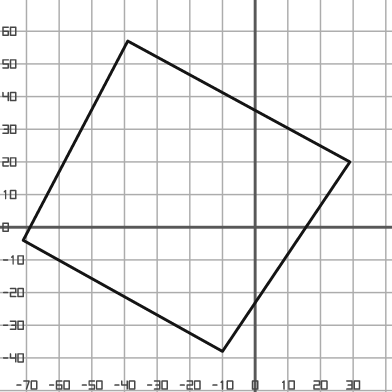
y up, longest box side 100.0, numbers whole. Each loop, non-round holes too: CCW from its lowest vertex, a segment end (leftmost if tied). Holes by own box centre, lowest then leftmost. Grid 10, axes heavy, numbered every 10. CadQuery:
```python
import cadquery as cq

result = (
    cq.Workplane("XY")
    .moveTo(-10.0, -38.0)
    .lineTo(29.0, 20.0)
    .lineTo(-39.0, 57.0)
    .lineTo(-71.0, -4.0)
    .close()
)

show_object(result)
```